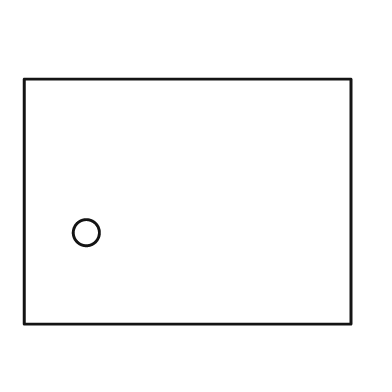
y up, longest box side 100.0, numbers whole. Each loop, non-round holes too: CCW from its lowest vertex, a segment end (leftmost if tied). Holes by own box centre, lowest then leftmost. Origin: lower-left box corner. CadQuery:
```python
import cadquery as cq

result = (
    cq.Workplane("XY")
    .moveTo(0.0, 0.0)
    .lineTo(100.0, 0.0)
    .lineTo(100.0, 75.0)
    .lineTo(0.0, 75.0)
    .close()
    .moveTo(19.0, 28.0)
    .circle(4.0)
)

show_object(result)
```